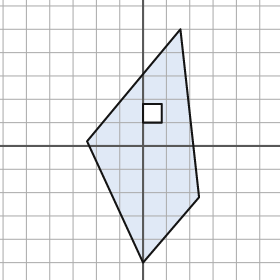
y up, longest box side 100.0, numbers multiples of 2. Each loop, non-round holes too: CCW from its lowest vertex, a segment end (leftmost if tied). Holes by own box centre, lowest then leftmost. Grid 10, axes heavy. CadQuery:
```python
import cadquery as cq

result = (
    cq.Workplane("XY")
    .moveTo(0.0, -50.0)
    .lineTo(24.0, -22.0)
    .lineTo(16.0, 50.0)
    .lineTo(-24.0, 2.0)
    .close()
    .moveTo(0.0, 10.0)
    .lineTo(8.0, 10.0)
    .lineTo(8.0, 18.0)
    .lineTo(0.0, 18.0)
    .close()
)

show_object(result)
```